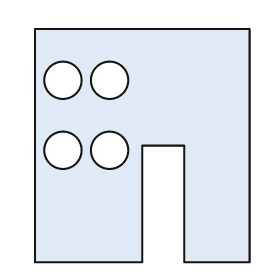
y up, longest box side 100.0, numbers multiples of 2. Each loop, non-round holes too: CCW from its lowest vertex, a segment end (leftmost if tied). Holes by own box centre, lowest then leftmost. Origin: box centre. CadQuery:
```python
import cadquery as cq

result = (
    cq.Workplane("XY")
    .moveTo(-46.0, -50.0)
    .lineTo(0.0, -50.0)
    .lineTo(0.0, 0.0)
    .lineTo(18.0, 0.0)
    .lineTo(18.0, -50.0)
    .lineTo(46.0, -50.0)
    .lineTo(46.0, 50.0)
    .lineTo(-46.0, 50.0)
    .close()
    .moveTo(-34.0, -2.0)
    .circle(8.0)
    .moveTo(-14.0, -2.0)
    .circle(8.0)
    .moveTo(-34.0, 28.0)
    .circle(8.0)
    .moveTo(-14.0, 28.0)
    .circle(8.0)
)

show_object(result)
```